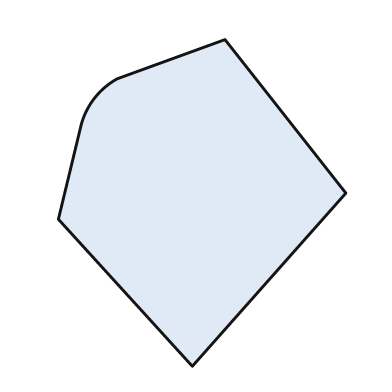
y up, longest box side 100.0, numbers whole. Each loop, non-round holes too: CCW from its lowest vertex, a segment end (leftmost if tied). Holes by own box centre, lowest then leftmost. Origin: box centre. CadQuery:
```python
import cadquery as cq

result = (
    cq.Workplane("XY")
    .moveTo(-3.0, -50.0)
    .lineTo(44.0, 3.0)
    .lineTo(7.0, 50.0)
    .lineTo(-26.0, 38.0)
    .threePointArc((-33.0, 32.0), (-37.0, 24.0))
    .lineTo(-44.0, -5.0)
    .close()
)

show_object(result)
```